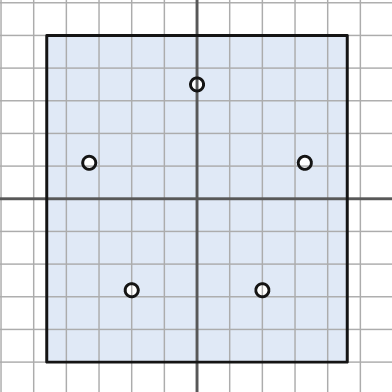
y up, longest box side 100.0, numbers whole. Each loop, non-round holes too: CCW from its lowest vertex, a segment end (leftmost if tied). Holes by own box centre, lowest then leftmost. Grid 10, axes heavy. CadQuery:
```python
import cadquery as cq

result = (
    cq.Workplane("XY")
    .moveTo(-46.0, -50.0)
    .lineTo(46.0, -50.0)
    .lineTo(46.0, 50.0)
    .lineTo(-46.0, 50.0)
    .close()
    .moveTo(-20.0, -28.0)
    .circle(2.0)
    .moveTo(20.0, -28.0)
    .circle(2.0)
    .moveTo(-33.0, 11.0)
    .circle(2.0)
    .moveTo(33.0, 11.0)
    .circle(2.0)
    .moveTo(0.0, 35.0)
    .circle(2.0)
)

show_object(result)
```